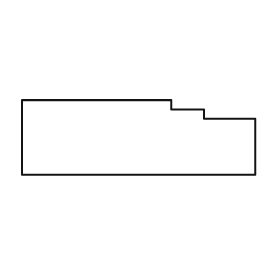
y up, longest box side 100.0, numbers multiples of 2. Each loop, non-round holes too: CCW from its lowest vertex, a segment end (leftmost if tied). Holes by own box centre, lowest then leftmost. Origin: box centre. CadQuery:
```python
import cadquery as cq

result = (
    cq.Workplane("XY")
    .moveTo(-50.0, -16.0)
    .lineTo(50.0, -16.0)
    .lineTo(50.0, 8.0)
    .lineTo(28.0, 8.0)
    .lineTo(28.0, 12.0)
    .lineTo(14.0, 12.0)
    .lineTo(14.0, 16.0)
    .lineTo(-50.0, 16.0)
    .close()
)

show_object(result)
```